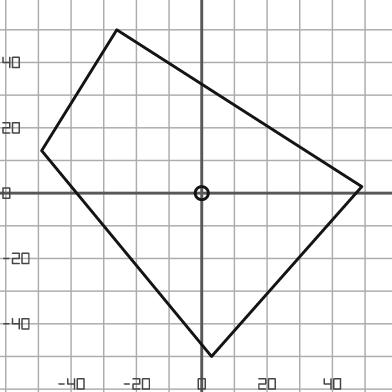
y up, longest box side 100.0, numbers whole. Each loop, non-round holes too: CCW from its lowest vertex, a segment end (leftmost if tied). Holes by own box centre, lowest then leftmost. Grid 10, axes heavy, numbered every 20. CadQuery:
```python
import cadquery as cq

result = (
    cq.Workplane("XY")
    .moveTo(3.0, -50.0)
    .lineTo(49.0, 2.0)
    .lineTo(-26.0, 50.0)
    .lineTo(-49.0, 13.0)
    .close()
    .moveTo(0.0, 0.0)
    .circle(2.0)
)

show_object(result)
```